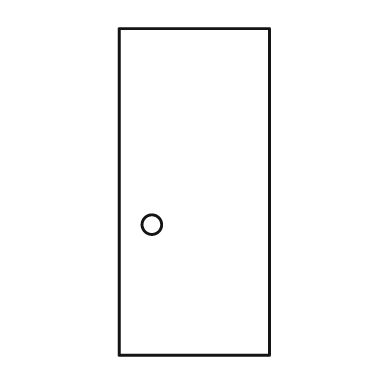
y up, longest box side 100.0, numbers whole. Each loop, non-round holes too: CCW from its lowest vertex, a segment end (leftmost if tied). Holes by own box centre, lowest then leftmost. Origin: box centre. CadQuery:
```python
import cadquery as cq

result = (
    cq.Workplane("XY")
    .moveTo(-23.0, -50.0)
    .lineTo(23.0, -50.0)
    .lineTo(23.0, 50.0)
    .lineTo(-23.0, 50.0)
    .close()
    .moveTo(-13.0, -10.0)
    .circle(3.0)
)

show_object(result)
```